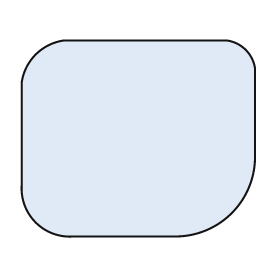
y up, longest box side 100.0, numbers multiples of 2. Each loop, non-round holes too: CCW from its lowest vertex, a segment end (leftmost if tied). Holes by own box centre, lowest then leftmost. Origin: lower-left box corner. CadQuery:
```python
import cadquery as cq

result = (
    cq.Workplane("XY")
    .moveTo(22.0, 0.0)
    .lineTo(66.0, 0.0)
    .threePointArc((90.0, 10.0), (100.0, 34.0))
    .lineTo(100.0, 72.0)
    .threePointArc((96.0, 80.0), (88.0, 84.0))
    .lineTo(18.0, 84.0)
    .threePointArc((6.0, 78.0), (0.0, 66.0))
    .lineTo(0.0, 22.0)
    .threePointArc((6.0, 6.0), (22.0, 0.0))
    .close()
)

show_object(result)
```